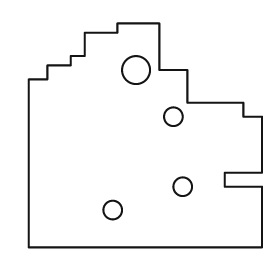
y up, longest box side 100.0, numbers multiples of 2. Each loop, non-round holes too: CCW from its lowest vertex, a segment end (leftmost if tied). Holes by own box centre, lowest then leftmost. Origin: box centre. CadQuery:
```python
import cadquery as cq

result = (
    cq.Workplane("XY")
    .moveTo(-50.0, -48.0)
    .lineTo(50.0, -48.0)
    .lineTo(50.0, -22.0)
    .lineTo(34.0, -22.0)
    .lineTo(34.0, -16.0)
    .lineTo(50.0, -16.0)
    .lineTo(50.0, 8.0)
    .lineTo(42.0, 8.0)
    .lineTo(42.0, 14.0)
    .lineTo(18.0, 14.0)
    .lineTo(18.0, 28.0)
    .lineTo(6.0, 28.0)
    .lineTo(6.0, 48.0)
    .lineTo(-12.0, 48.0)
    .lineTo(-12.0, 44.0)
    .lineTo(-26.0, 44.0)
    .lineTo(-26.0, 34.0)
    .lineTo(-32.0, 34.0)
    .lineTo(-32.0, 30.0)
    .lineTo(-42.0, 30.0)
    .lineTo(-42.0, 24.0)
    .lineTo(-50.0, 24.0)
    .close()
    .moveTo(-14.0, -32.0)
    .circle(4.0)
    .moveTo(16.0, -22.0)
    .circle(4.0)
    .moveTo(12.0, 8.0)
    .circle(4.0)
    .moveTo(-4.0, 28.0)
    .circle(6.0)
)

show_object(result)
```